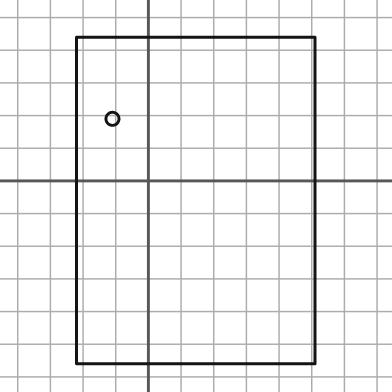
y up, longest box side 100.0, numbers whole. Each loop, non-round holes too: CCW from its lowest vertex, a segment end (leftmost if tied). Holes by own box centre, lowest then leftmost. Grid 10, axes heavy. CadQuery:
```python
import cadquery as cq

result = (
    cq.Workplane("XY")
    .moveTo(-22.0, -56.0)
    .lineTo(51.0, -56.0)
    .lineTo(51.0, 44.0)
    .lineTo(-22.0, 44.0)
    .close()
    .moveTo(-11.0, 19.0)
    .circle(2.0)
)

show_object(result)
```